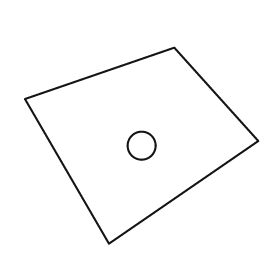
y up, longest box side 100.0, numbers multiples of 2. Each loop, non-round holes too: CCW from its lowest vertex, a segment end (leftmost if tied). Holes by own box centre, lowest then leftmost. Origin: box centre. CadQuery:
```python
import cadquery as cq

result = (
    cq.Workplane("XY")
    .moveTo(-14.0, -42.0)
    .lineTo(50.0, 2.0)
    .lineTo(14.0, 42.0)
    .lineTo(-50.0, 20.0)
    .close()
    .moveTo(0.0, 0.0)
    .circle(6.0)
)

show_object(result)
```